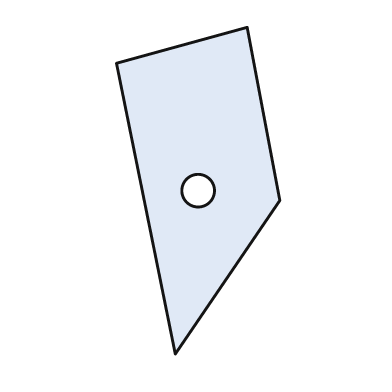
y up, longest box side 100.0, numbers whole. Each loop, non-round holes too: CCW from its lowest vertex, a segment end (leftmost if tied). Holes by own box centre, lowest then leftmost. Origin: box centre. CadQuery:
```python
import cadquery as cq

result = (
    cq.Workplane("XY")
    .moveTo(-7.0, -50.0)
    .lineTo(25.0, -3.0)
    .lineTo(15.0, 50.0)
    .lineTo(-25.0, 39.0)
    .close()
    .moveTo(0.0, 0.0)
    .circle(5.0)
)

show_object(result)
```